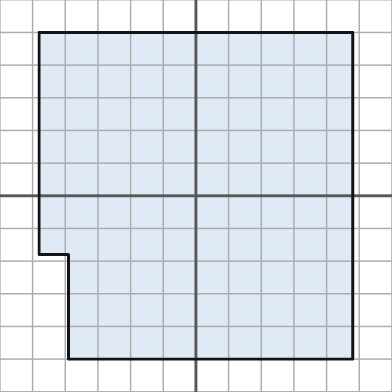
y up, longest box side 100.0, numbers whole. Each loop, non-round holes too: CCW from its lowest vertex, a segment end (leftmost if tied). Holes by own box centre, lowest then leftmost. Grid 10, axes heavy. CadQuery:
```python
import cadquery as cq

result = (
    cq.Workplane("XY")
    .moveTo(-39.0, -50.0)
    .lineTo(48.0, -50.0)
    .lineTo(48.0, 50.0)
    .lineTo(-48.0, 50.0)
    .lineTo(-48.0, -18.0)
    .lineTo(-39.0, -18.0)
    .close()
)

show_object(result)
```